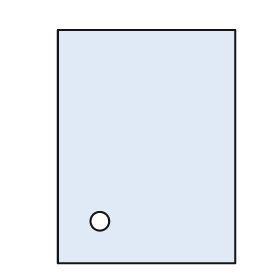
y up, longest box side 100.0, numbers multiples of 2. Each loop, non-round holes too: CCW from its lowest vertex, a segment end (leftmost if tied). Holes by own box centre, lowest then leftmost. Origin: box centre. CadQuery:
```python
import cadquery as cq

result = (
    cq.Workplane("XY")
    .moveTo(-38.0, -50.0)
    .lineTo(38.0, -50.0)
    .lineTo(38.0, 50.0)
    .lineTo(-38.0, 50.0)
    .close()
    .moveTo(-20.0, -32.0)
    .circle(4.0)
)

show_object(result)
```